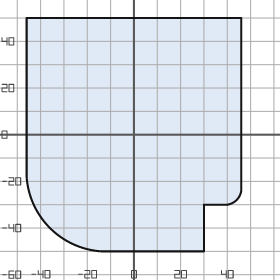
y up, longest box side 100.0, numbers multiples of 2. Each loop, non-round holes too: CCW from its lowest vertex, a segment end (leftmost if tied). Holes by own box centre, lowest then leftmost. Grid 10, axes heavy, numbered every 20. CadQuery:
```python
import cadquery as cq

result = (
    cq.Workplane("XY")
    .moveTo(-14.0, -50.0)
    .lineTo(30.0, -50.0)
    .lineTo(30.0, -30.0)
    .lineTo(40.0, -30.0)
    .threePointArc((44.0, -28.0), (46.0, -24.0))
    .lineTo(46.0, 50.0)
    .lineTo(-46.0, 50.0)
    .lineTo(-46.0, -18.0)
    .threePointArc((-36.0, -40.0), (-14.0, -50.0))
    .close()
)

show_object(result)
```